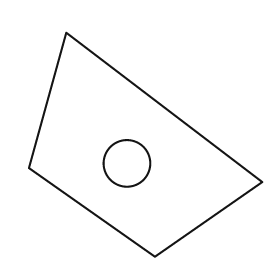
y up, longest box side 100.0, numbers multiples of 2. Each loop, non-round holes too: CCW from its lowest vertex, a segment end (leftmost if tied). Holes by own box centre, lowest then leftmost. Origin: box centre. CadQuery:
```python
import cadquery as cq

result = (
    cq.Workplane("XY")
    .moveTo(4.0, -48.0)
    .lineTo(50.0, -16.0)
    .lineTo(-34.0, 48.0)
    .lineTo(-50.0, -10.0)
    .close()
    .moveTo(-8.0, -8.0)
    .circle(10.0)
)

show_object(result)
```